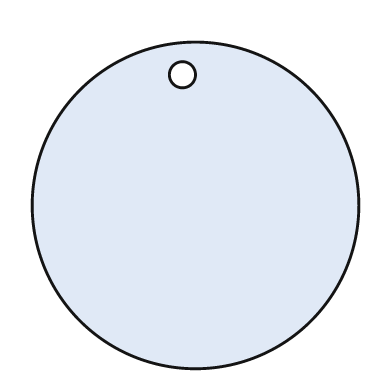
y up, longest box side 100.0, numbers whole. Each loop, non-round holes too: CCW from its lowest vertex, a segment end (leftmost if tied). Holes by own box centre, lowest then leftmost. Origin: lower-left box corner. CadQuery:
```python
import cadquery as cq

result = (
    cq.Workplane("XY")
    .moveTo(50.0, 50.0)
    .circle(50.0)
    .moveTo(46.0, 90.0)
    .circle(4.0)
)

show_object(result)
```